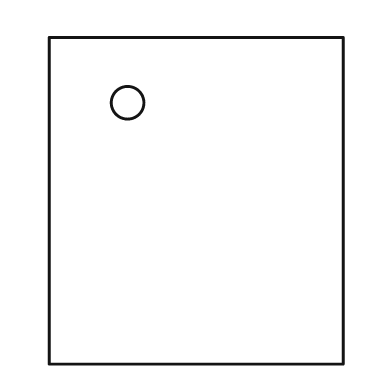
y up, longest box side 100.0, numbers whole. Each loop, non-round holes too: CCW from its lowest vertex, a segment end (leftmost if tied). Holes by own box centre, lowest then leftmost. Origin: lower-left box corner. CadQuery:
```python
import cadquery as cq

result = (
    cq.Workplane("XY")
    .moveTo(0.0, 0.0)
    .lineTo(90.0, 0.0)
    .lineTo(90.0, 100.0)
    .lineTo(0.0, 100.0)
    .close()
    .moveTo(24.0, 80.0)
    .circle(5.0)
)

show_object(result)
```